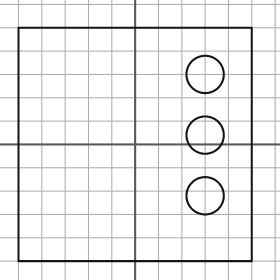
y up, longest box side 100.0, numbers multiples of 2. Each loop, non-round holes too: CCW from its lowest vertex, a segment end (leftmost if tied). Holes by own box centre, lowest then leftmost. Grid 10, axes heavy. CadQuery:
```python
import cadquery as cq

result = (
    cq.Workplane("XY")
    .moveTo(-50.0, -50.0)
    .lineTo(50.0, -50.0)
    .lineTo(50.0, 50.0)
    .lineTo(-50.0, 50.0)
    .close()
    .moveTo(30.0, -22.0)
    .circle(8.0)
    .moveTo(30.0, 4.0)
    .circle(8.0)
    .moveTo(30.0, 30.0)
    .circle(8.0)
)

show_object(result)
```